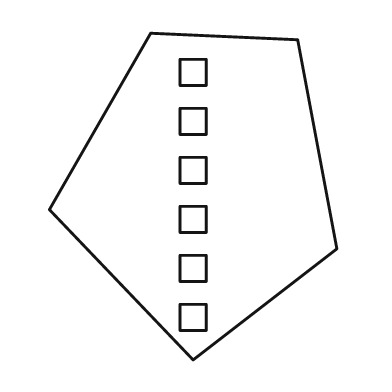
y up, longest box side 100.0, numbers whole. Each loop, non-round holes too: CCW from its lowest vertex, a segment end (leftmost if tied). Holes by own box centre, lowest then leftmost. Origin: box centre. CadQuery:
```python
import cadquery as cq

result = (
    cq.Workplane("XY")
    .moveTo(0.0, -50.0)
    .lineTo(44.0, -16.0)
    .lineTo(32.0, 48.0)
    .lineTo(-13.0, 50.0)
    .lineTo(-44.0, -4.0)
    .close()
    .moveTo(-4.0, -41.0)
    .lineTo(4.0, -41.0)
    .lineTo(4.0, -33.0)
    .lineTo(-4.0, -33.0)
    .close()
    .moveTo(-4.0, -26.0)
    .lineTo(4.0, -26.0)
    .lineTo(4.0, -18.0)
    .lineTo(-4.0, -18.0)
    .close()
    .moveTo(-4.0, -11.0)
    .lineTo(4.0, -11.0)
    .lineTo(4.0, -3.0)
    .lineTo(-4.0, -3.0)
    .close()
    .moveTo(-4.0, 4.0)
    .lineTo(4.0, 4.0)
    .lineTo(4.0, 12.0)
    .lineTo(-4.0, 12.0)
    .close()
    .moveTo(-4.0, 19.0)
    .lineTo(4.0, 19.0)
    .lineTo(4.0, 27.0)
    .lineTo(-4.0, 27.0)
    .close()
    .moveTo(-4.0, 34.0)
    .lineTo(4.0, 34.0)
    .lineTo(4.0, 42.0)
    .lineTo(-4.0, 42.0)
    .close()
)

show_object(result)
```